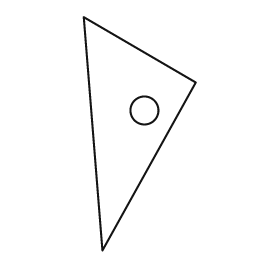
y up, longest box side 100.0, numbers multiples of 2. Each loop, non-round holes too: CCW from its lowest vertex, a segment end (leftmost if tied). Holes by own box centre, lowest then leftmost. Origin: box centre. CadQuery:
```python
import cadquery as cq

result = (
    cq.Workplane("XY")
    .moveTo(-16.0, -50.0)
    .lineTo(24.0, 22.0)
    .lineTo(-24.0, 50.0)
    .close()
    .moveTo(2.0, 10.0)
    .circle(6.0)
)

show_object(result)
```